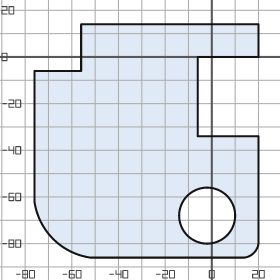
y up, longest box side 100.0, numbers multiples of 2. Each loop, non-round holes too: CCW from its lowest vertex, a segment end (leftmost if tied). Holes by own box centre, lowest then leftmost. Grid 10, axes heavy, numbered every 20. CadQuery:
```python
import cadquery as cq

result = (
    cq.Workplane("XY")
    .moveTo(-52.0, -86.0)
    .lineTo(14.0, -86.0)
    .threePointArc((18.0, -84.0), (20.0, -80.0))
    .lineTo(20.0, -34.0)
    .lineTo(-6.0, -34.0)
    .lineTo(-6.0, 0.0)
    .lineTo(20.0, 0.0)
    .lineTo(20.0, 14.0)
    .lineTo(-56.0, 14.0)
    .lineTo(-56.0, -6.0)
    .lineTo(-76.0, -6.0)
    .lineTo(-76.0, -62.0)
    .threePointArc((-68.0, -78.0), (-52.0, -86.0))
    .close()
    .moveTo(-2.0, -68.0)
    .circle(12.0)
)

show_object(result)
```